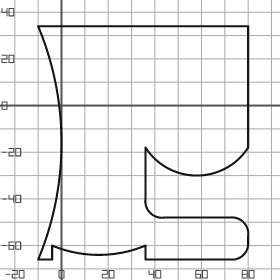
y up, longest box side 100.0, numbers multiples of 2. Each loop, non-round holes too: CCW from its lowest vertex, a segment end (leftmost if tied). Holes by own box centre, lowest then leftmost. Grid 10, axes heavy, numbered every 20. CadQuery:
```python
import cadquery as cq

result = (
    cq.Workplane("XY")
    .moveTo(-10.0, -66.0)
    .lineTo(-4.0, -66.0)
    .lineTo(-4.0, -60.0)
    .threePointArc((16.0, -64.0), (36.0, -60.0))
    .lineTo(36.0, -66.0)
    .lineTo(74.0, -66.0)
    .threePointArc((78.0, -64.0), (80.0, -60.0))
    .lineTo(80.0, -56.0)
    .threePointArc((78.0, -50.0), (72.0, -48.0))
    .lineTo(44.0, -48.0)
    .threePointArc((38.0, -46.0), (36.0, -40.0))
    .lineTo(36.0, -18.0)
    .threePointArc((58.0, -30.0), (80.0, -18.0))
    .lineTo(80.0, 34.0)
    .lineTo(-10.0, 34.0)
    .threePointArc((0.0, -16.0), (-10.0, -66.0))
    .close()
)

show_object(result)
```